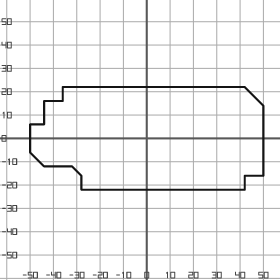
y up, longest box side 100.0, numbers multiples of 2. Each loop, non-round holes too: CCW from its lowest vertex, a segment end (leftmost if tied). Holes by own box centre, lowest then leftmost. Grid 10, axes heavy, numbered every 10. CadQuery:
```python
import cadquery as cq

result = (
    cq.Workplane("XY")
    .moveTo(-28.0, -22.0)
    .lineTo(42.0, -22.0)
    .lineTo(42.0, -16.0)
    .lineTo(50.0, -16.0)
    .lineTo(50.0, 14.0)
    .lineTo(42.0, 22.0)
    .lineTo(-36.0, 22.0)
    .lineTo(-36.0, 16.0)
    .lineTo(-44.0, 16.0)
    .lineTo(-44.0, 6.0)
    .lineTo(-50.0, 6.0)
    .lineTo(-50.0, -6.0)
    .lineTo(-44.0, -12.0)
    .lineTo(-32.0, -12.0)
    .lineTo(-28.0, -16.0)
    .close()
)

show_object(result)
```